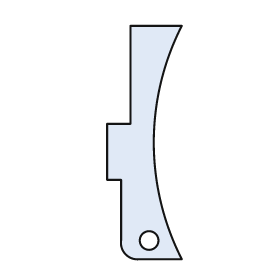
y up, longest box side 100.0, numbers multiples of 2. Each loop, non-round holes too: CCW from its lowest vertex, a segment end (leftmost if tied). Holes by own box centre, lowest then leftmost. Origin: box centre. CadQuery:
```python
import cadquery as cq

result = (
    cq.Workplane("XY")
    .moveTo(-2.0, -50.0)
    .lineTo(16.0, -50.0)
    .threePointArc((4.0, 0.0), (16.0, 50.0))
    .lineTo(-6.0, 50.0)
    .lineTo(-6.0, 8.0)
    .lineTo(-16.0, 8.0)
    .lineTo(-16.0, -16.0)
    .lineTo(-10.0, -16.0)
    .lineTo(-10.0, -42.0)
    .threePointArc((-8.0, -48.0), (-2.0, -50.0))
    .close()
    .moveTo(2.0, -42.0)
    .circle(4.0)
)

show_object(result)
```